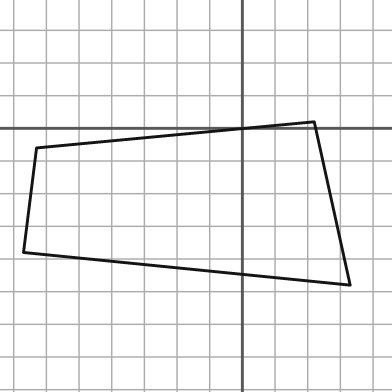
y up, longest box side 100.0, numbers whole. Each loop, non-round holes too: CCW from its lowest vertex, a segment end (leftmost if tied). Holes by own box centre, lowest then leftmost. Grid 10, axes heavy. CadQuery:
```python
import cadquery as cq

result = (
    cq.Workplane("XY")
    .moveTo(33.0, -48.0)
    .lineTo(22.0, 2.0)
    .lineTo(-63.0, -6.0)
    .lineTo(-67.0, -38.0)
    .close()
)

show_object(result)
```